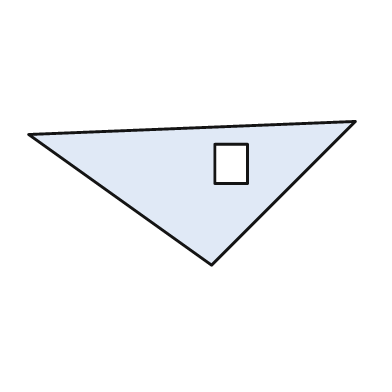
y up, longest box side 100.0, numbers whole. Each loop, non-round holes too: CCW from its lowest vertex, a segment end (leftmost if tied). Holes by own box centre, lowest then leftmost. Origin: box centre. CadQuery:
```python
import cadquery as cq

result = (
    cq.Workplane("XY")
    .moveTo(6.0, -22.0)
    .lineTo(50.0, 22.0)
    .lineTo(-50.0, 18.0)
    .close()
    .moveTo(7.0, 3.0)
    .lineTo(17.0, 3.0)
    .lineTo(17.0, 15.0)
    .lineTo(7.0, 15.0)
    .close()
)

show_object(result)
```